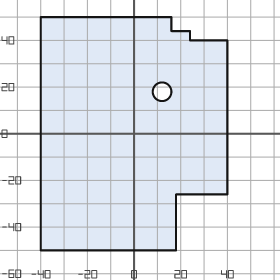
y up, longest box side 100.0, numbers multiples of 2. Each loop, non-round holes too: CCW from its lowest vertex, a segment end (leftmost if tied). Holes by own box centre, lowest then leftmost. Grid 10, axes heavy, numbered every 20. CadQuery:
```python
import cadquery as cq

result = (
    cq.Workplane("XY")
    .moveTo(-40.0, -50.0)
    .lineTo(18.0, -50.0)
    .lineTo(18.0, -26.0)
    .lineTo(40.0, -26.0)
    .lineTo(40.0, 40.0)
    .lineTo(24.0, 40.0)
    .lineTo(24.0, 44.0)
    .lineTo(16.0, 44.0)
    .lineTo(16.0, 50.0)
    .lineTo(-40.0, 50.0)
    .close()
    .moveTo(12.0, 18.0)
    .circle(4.0)
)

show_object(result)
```